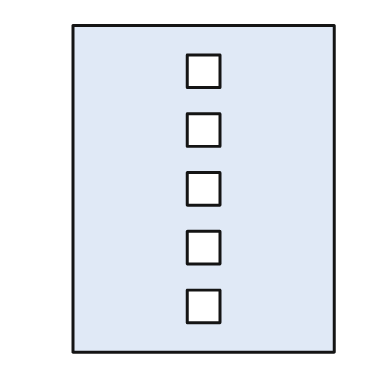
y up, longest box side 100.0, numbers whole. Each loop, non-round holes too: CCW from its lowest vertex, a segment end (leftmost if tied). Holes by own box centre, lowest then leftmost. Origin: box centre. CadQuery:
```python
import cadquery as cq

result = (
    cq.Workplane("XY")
    .moveTo(-40.0, -50.0)
    .lineTo(40.0, -50.0)
    .lineTo(40.0, 50.0)
    .lineTo(-40.0, 50.0)
    .close()
    .moveTo(-5.0, -41.0)
    .lineTo(5.0, -41.0)
    .lineTo(5.0, -31.0)
    .lineTo(-5.0, -31.0)
    .close()
    .moveTo(-5.0, -23.0)
    .lineTo(5.0, -23.0)
    .lineTo(5.0, -13.0)
    .lineTo(-5.0, -13.0)
    .close()
    .moveTo(-5.0, -5.0)
    .lineTo(5.0, -5.0)
    .lineTo(5.0, 5.0)
    .lineTo(-5.0, 5.0)
    .close()
    .moveTo(-5.0, 13.0)
    .lineTo(5.0, 13.0)
    .lineTo(5.0, 23.0)
    .lineTo(-5.0, 23.0)
    .close()
    .moveTo(-5.0, 31.0)
    .lineTo(5.0, 31.0)
    .lineTo(5.0, 41.0)
    .lineTo(-5.0, 41.0)
    .close()
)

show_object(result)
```